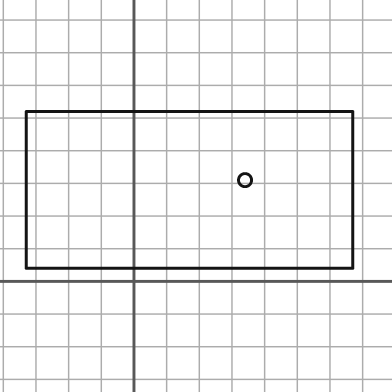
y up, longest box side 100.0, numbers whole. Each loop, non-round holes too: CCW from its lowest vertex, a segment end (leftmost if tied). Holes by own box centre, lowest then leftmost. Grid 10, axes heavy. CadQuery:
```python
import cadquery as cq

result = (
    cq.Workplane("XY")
    .moveTo(-33.0, 4.0)
    .lineTo(67.0, 4.0)
    .lineTo(67.0, 52.0)
    .lineTo(-33.0, 52.0)
    .close()
    .moveTo(34.0, 31.0)
    .circle(2.0)
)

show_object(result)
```